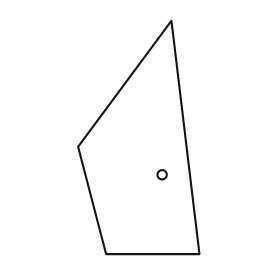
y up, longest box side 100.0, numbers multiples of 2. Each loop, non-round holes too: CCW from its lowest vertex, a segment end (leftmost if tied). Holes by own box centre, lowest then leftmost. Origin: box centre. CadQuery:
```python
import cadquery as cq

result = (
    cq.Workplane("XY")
    .moveTo(-14.0, -50.0)
    .lineTo(26.0, -50.0)
    .lineTo(14.0, 50.0)
    .lineTo(-26.0, -4.0)
    .close()
    .moveTo(10.0, -16.0)
    .circle(2.0)
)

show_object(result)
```